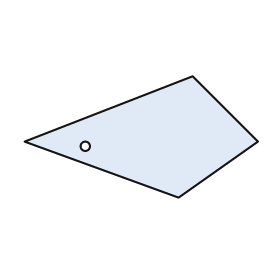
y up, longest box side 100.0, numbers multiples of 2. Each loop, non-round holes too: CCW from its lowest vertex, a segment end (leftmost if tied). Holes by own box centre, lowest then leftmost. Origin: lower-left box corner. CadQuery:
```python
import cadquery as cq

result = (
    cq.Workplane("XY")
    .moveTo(66.0, 0.0)
    .lineTo(100.0, 24.0)
    .lineTo(72.0, 52.0)
    .lineTo(0.0, 24.0)
    .close()
    .moveTo(26.0, 22.0)
    .circle(2.0)
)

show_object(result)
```